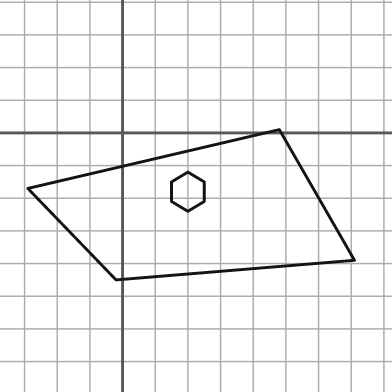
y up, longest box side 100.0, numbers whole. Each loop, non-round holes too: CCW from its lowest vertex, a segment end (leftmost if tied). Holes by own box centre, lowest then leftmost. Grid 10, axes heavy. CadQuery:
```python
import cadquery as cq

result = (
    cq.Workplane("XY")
    .moveTo(-2.0, -45.0)
    .lineTo(71.0, -39.0)
    .lineTo(48.0, 1.0)
    .lineTo(-29.0, -17.0)
    .close()
    .moveTo(20.0, -24.0)
    .lineTo(25.0, -21.0)
    .lineTo(25.0, -15.0)
    .lineTo(20.0, -12.0)
    .lineTo(15.0, -15.0)
    .lineTo(15.0, -21.0)
    .close()
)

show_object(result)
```